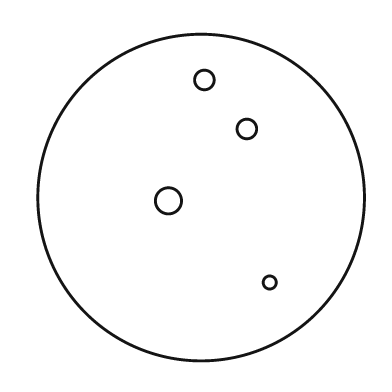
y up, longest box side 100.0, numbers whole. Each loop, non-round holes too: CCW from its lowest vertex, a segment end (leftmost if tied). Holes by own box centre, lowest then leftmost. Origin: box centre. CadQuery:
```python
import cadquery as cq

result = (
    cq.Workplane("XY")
    .moveTo(0.0, 0.0)
    .circle(50.0)
    .moveTo(21.0, -26.0)
    .circle(2.0)
    .moveTo(-10.0, -1.0)
    .circle(4.0)
    .moveTo(14.0, 21.0)
    .circle(3.0)
    .moveTo(1.0, 36.0)
    .circle(3.0)
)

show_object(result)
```